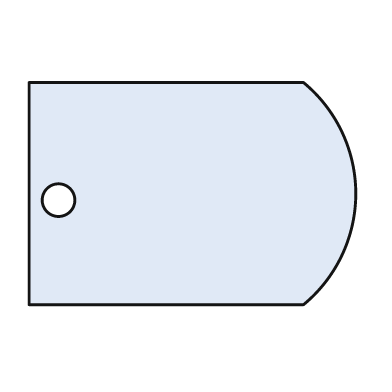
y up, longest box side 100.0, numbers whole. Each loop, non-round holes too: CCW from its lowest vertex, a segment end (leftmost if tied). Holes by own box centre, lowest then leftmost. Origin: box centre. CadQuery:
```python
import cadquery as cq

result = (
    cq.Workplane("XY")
    .moveTo(-50.0, -34.0)
    .lineTo(34.0, -34.0)
    .threePointArc((50.0, 0.0), (34.0, 34.0))
    .lineTo(-50.0, 34.0)
    .close()
    .moveTo(-41.0, -2.0)
    .circle(5.0)
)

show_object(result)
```